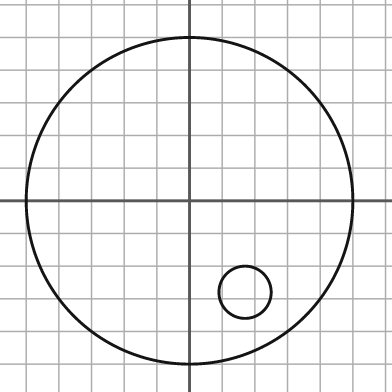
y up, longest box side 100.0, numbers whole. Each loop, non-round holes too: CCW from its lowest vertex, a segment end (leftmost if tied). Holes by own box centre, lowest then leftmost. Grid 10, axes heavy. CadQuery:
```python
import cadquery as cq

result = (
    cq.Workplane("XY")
    .moveTo(0.0, 0.0)
    .circle(50.0)
    .moveTo(17.0, -28.0)
    .circle(8.0)
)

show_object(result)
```